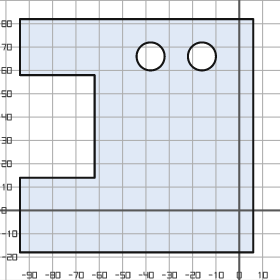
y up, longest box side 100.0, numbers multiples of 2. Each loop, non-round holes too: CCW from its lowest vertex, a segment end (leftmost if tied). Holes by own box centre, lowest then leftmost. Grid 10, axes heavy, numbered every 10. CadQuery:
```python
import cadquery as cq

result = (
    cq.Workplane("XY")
    .moveTo(-94.0, -18.0)
    .lineTo(6.0, -18.0)
    .lineTo(6.0, 82.0)
    .lineTo(-94.0, 82.0)
    .lineTo(-94.0, 58.0)
    .lineTo(-62.0, 58.0)
    .lineTo(-62.0, 14.0)
    .lineTo(-94.0, 14.0)
    .close()
    .moveTo(-38.0, 66.0)
    .circle(6.0)
    .moveTo(-16.0, 66.0)
    .circle(6.0)
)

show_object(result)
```